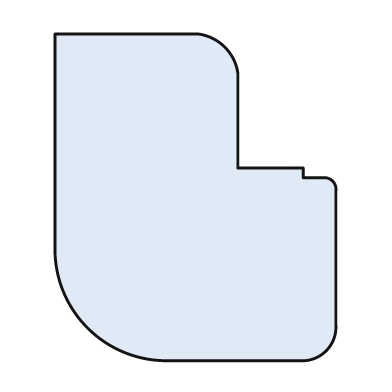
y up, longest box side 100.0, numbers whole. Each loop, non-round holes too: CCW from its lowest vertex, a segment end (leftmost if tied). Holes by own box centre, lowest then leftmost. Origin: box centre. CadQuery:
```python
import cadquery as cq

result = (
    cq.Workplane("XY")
    .moveTo(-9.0, -50.0)
    .lineTo(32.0, -50.0)
    .threePointArc((40.0, -47.0), (43.0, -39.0))
    .lineTo(43.0, 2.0)
    .threePointArc((42.0, 5.0), (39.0, 6.0))
    .lineTo(33.0, 6.0)
    .lineTo(33.0, 9.0)
    .lineTo(13.0, 9.0)
    .lineTo(13.0, 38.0)
    .threePointArc((9.0, 46.0), (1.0, 50.0))
    .lineTo(-43.0, 50.0)
    .lineTo(-43.0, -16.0)
    .threePointArc((-33.0, -40.0), (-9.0, -50.0))
    .close()
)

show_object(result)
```